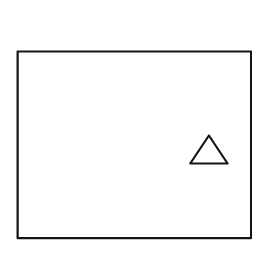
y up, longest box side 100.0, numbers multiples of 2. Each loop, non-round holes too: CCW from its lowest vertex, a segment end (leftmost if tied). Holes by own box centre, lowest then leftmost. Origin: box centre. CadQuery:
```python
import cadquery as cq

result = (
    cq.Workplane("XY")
    .moveTo(-50.0, -40.0)
    .lineTo(50.0, -40.0)
    .lineTo(50.0, 40.0)
    .lineTo(-50.0, 40.0)
    .close()
    .moveTo(24.0, -8.0)
    .lineTo(40.0, -8.0)
    .lineTo(32.0, 4.0)
    .close()
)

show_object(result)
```